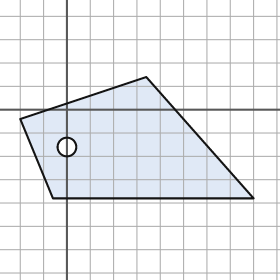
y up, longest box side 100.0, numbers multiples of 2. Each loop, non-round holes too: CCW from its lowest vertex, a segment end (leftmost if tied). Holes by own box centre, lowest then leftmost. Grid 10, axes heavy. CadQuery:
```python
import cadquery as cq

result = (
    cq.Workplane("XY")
    .moveTo(-6.0, -38.0)
    .lineTo(80.0, -38.0)
    .lineTo(34.0, 14.0)
    .lineTo(-20.0, -4.0)
    .close()
    .moveTo(0.0, -16.0)
    .circle(4.0)
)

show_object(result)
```